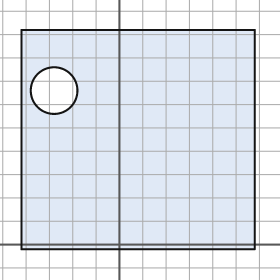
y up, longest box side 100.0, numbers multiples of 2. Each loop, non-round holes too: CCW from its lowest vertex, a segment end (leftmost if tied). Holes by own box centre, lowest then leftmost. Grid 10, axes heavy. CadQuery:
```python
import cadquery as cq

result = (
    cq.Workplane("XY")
    .moveTo(-42.0, -2.0)
    .lineTo(58.0, -2.0)
    .lineTo(58.0, 92.0)
    .lineTo(-42.0, 92.0)
    .close()
    .moveTo(-28.0, 66.0)
    .circle(10.0)
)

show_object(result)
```